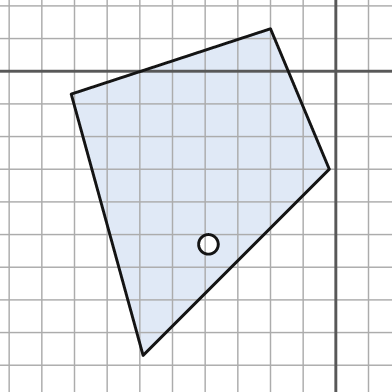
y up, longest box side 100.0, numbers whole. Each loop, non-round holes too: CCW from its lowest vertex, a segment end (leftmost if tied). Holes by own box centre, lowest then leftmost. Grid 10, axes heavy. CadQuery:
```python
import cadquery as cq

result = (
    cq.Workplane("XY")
    .moveTo(-59.0, -87.0)
    .lineTo(-2.0, -30.0)
    .lineTo(-20.0, 13.0)
    .lineTo(-81.0, -7.0)
    .close()
    .moveTo(-39.0, -53.0)
    .circle(3.0)
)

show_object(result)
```